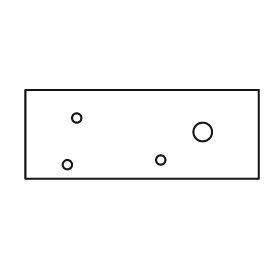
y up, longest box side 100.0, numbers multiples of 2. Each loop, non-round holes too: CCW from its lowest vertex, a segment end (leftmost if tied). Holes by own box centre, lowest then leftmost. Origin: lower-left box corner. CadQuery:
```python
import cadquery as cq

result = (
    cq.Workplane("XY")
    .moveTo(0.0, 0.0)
    .lineTo(100.0, 0.0)
    .lineTo(100.0, 38.0)
    .lineTo(0.0, 38.0)
    .close()
    .moveTo(18.0, 6.0)
    .circle(2.0)
    .moveTo(58.0, 8.0)
    .circle(2.0)
    .moveTo(76.0, 20.0)
    .circle(4.0)
    .moveTo(22.0, 26.0)
    .circle(2.0)
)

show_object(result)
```